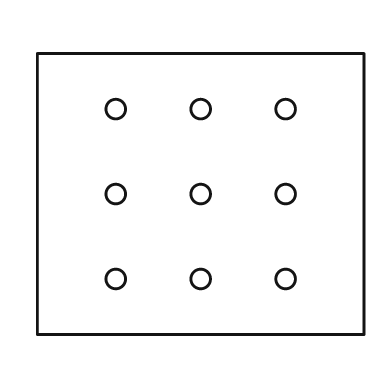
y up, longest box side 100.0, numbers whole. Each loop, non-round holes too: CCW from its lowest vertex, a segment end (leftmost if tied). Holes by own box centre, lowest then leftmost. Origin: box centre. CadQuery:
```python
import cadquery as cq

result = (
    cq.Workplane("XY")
    .moveTo(-50.0, -43.0)
    .lineTo(50.0, -43.0)
    .lineTo(50.0, 43.0)
    .lineTo(-50.0, 43.0)
    .close()
    .moveTo(-26.0, -26.0)
    .circle(3.0)
    .moveTo(0.0, -26.0)
    .circle(3.0)
    .moveTo(26.0, -26.0)
    .circle(3.0)
    .moveTo(-26.0, 0.0)
    .circle(3.0)
    .moveTo(0.0, 0.0)
    .circle(3.0)
    .moveTo(26.0, 0.0)
    .circle(3.0)
    .moveTo(-26.0, 26.0)
    .circle(3.0)
    .moveTo(0.0, 26.0)
    .circle(3.0)
    .moveTo(26.0, 26.0)
    .circle(3.0)
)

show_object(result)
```